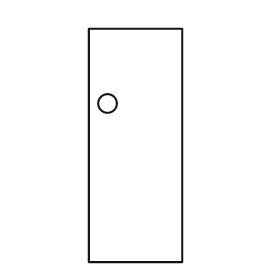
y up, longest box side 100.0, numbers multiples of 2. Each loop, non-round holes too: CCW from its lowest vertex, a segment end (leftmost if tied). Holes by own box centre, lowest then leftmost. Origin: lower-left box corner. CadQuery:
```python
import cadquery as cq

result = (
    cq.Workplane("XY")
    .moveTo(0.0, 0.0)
    .lineTo(40.0, 0.0)
    .lineTo(40.0, 100.0)
    .lineTo(0.0, 100.0)
    .close()
    .moveTo(8.0, 68.0)
    .circle(4.0)
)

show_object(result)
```